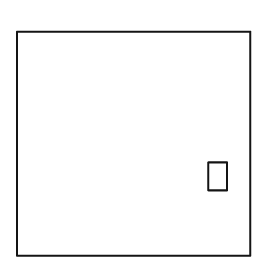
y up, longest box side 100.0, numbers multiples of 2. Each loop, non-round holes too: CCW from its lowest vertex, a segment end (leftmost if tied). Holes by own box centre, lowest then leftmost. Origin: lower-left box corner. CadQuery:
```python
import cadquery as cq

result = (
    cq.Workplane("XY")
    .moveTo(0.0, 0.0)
    .lineTo(100.0, 0.0)
    .lineTo(100.0, 96.0)
    .lineTo(0.0, 96.0)
    .close()
    .moveTo(82.0, 28.0)
    .lineTo(90.0, 28.0)
    .lineTo(90.0, 40.0)
    .lineTo(82.0, 40.0)
    .close()
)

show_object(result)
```